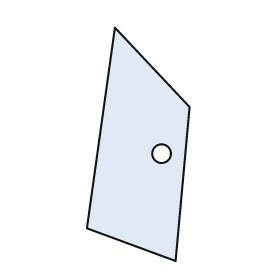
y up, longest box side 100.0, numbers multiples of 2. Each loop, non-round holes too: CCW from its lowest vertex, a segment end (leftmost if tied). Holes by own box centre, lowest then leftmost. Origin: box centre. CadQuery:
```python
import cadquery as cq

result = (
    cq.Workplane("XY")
    .moveTo(16.0, -50.0)
    .lineTo(22.0, 16.0)
    .lineTo(-10.0, 50.0)
    .lineTo(-22.0, -36.0)
    .close()
    .moveTo(10.0, -4.0)
    .circle(4.0)
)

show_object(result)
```